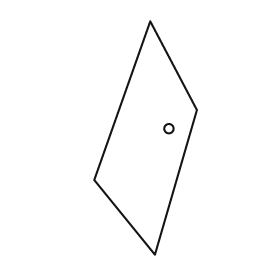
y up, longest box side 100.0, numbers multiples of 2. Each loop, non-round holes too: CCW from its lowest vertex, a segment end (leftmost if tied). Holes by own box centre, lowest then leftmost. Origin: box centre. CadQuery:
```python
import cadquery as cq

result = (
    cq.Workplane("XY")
    .moveTo(4.0, -50.0)
    .lineTo(22.0, 12.0)
    .lineTo(2.0, 50.0)
    .lineTo(-22.0, -18.0)
    .close()
    .moveTo(10.0, 4.0)
    .circle(2.0)
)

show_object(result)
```